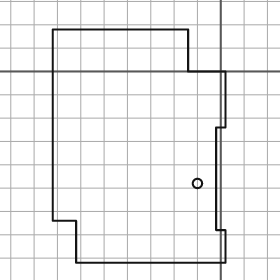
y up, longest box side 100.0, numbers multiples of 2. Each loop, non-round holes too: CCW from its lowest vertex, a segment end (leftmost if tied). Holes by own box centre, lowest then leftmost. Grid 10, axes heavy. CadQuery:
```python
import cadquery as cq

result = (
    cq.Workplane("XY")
    .moveTo(-62.0, -82.0)
    .lineTo(2.0, -82.0)
    .lineTo(2.0, -68.0)
    .lineTo(-2.0, -68.0)
    .lineTo(-2.0, -24.0)
    .lineTo(2.0, -24.0)
    .lineTo(2.0, 0.0)
    .lineTo(-14.0, 0.0)
    .lineTo(-14.0, 18.0)
    .lineTo(-72.0, 18.0)
    .lineTo(-72.0, -64.0)
    .lineTo(-62.0, -64.0)
    .close()
    .moveTo(-10.0, -48.0)
    .circle(2.0)
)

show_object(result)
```